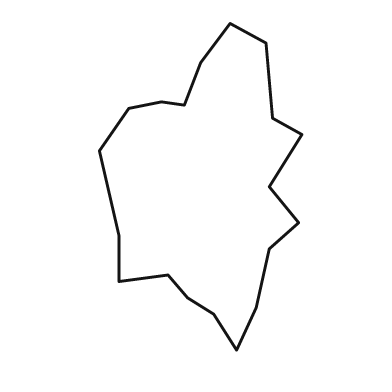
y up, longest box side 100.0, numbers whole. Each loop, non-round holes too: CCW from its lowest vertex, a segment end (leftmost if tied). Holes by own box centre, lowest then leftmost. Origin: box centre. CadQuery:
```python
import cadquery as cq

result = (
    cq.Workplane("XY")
    .moveTo(11.0, -50.0)
    .lineTo(17.0, -37.0)
    .lineTo(21.0, -19.0)
    .lineTo(30.0, -11.0)
    .lineTo(21.0, 0.0)
    .lineTo(31.0, 16.0)
    .lineTo(22.0, 21.0)
    .lineTo(20.0, 44.0)
    .lineTo(9.0, 50.0)
    .lineTo(0.0, 38.0)
    .lineTo(-5.0, 25.0)
    .lineTo(-12.0, 26.0)
    .lineTo(-22.0, 24.0)
    .lineTo(-31.0, 11.0)
    .lineTo(-25.0, -15.0)
    .lineTo(-25.0, -29.0)
    .lineTo(-10.0, -27.0)
    .lineTo(-4.0, -34.0)
    .lineTo(4.0, -39.0)
    .close()
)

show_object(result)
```